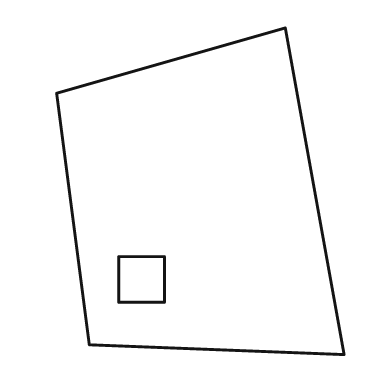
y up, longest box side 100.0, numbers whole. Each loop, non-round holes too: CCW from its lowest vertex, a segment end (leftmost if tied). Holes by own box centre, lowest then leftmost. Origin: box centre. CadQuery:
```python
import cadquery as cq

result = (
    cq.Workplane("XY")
    .moveTo(44.0, -50.0)
    .lineTo(26.0, 50.0)
    .lineTo(-44.0, 30.0)
    .lineTo(-34.0, -47.0)
    .close()
    .moveTo(-25.0, -34.0)
    .lineTo(-11.0, -34.0)
    .lineTo(-11.0, -20.0)
    .lineTo(-25.0, -20.0)
    .close()
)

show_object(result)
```